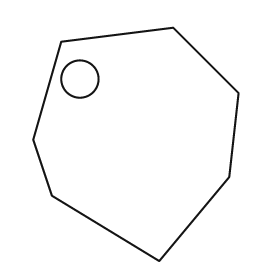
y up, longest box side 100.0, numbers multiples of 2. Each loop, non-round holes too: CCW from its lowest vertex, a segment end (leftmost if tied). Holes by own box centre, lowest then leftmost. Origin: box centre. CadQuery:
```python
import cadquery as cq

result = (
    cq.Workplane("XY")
    .moveTo(10.0, -50.0)
    .lineTo(40.0, -14.0)
    .lineTo(44.0, 22.0)
    .lineTo(16.0, 50.0)
    .lineTo(-32.0, 44.0)
    .lineTo(-44.0, 2.0)
    .lineTo(-36.0, -22.0)
    .close()
    .moveTo(-24.0, 28.0)
    .circle(8.0)
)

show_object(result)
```